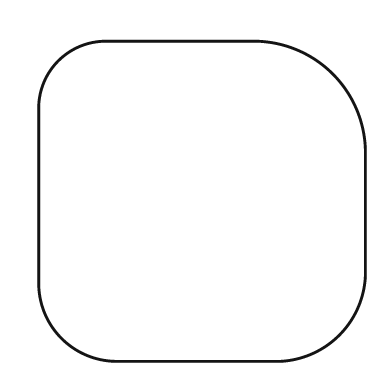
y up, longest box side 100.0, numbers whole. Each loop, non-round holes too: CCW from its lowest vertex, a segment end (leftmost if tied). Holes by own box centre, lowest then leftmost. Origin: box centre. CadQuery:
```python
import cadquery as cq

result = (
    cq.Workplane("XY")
    .moveTo(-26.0, -49.0)
    .lineTo(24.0, -49.0)
    .threePointArc((42.0, -41.0), (50.0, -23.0))
    .lineTo(50.0, 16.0)
    .threePointArc((40.0, 39.0), (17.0, 49.0))
    .lineTo(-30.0, 49.0)
    .threePointArc((-44.0, 43.0), (-50.0, 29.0))
    .lineTo(-50.0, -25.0)
    .threePointArc((-43.0, -42.0), (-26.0, -49.0))
    .close()
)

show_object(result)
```